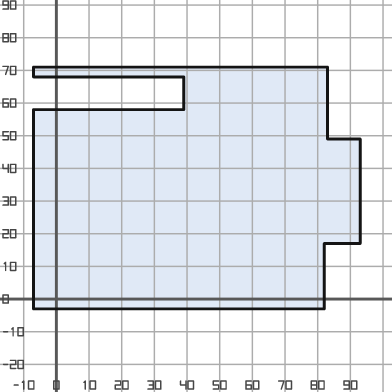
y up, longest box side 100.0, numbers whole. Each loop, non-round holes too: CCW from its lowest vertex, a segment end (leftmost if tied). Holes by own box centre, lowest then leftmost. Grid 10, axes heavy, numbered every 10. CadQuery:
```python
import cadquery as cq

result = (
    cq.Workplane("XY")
    .moveTo(-7.0, -3.0)
    .lineTo(82.0, -3.0)
    .lineTo(82.0, 17.0)
    .lineTo(93.0, 17.0)
    .lineTo(93.0, 49.0)
    .lineTo(83.0, 49.0)
    .lineTo(83.0, 71.0)
    .lineTo(-7.0, 71.0)
    .lineTo(-7.0, 68.0)
    .lineTo(39.0, 68.0)
    .lineTo(39.0, 58.0)
    .lineTo(-7.0, 58.0)
    .close()
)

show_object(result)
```